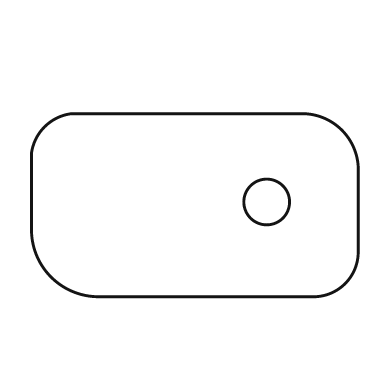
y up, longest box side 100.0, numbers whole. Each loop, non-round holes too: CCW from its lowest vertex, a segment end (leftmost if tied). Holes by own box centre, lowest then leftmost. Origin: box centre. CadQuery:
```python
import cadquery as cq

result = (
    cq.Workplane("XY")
    .moveTo(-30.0, -28.0)
    .lineTo(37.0, -28.0)
    .threePointArc((46.0, -24.0), (50.0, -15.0))
    .lineTo(50.0, 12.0)
    .threePointArc((45.0, 23.0), (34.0, 28.0))
    .lineTo(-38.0, 28.0)
    .threePointArc((-46.0, 24.0), (-50.0, 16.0))
    .lineTo(-50.0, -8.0)
    .threePointArc((-44.0, -22.0), (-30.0, -28.0))
    .close()
    .moveTo(22.0, 1.0)
    .circle(7.0)
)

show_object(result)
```